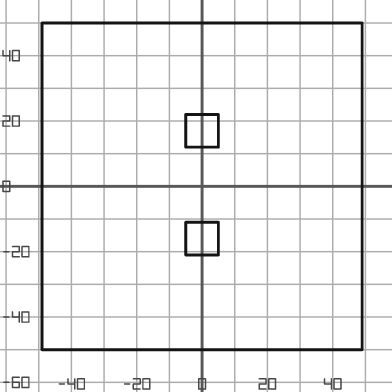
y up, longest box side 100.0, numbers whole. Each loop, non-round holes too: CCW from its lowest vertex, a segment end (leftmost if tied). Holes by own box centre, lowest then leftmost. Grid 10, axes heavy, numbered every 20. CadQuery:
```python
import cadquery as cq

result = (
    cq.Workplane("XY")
    .moveTo(-49.0, -50.0)
    .lineTo(49.0, -50.0)
    .lineTo(49.0, 50.0)
    .lineTo(-49.0, 50.0)
    .close()
    .moveTo(-5.0, -21.0)
    .lineTo(5.0, -21.0)
    .lineTo(5.0, -11.0)
    .lineTo(-5.0, -11.0)
    .close()
    .moveTo(-5.0, 12.0)
    .lineTo(5.0, 12.0)
    .lineTo(5.0, 22.0)
    .lineTo(-5.0, 22.0)
    .close()
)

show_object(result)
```